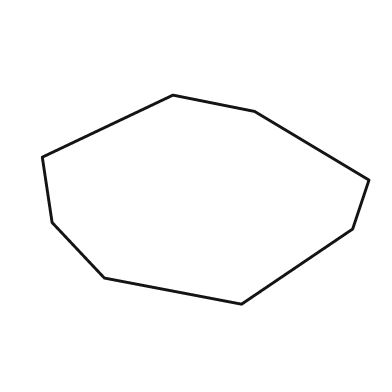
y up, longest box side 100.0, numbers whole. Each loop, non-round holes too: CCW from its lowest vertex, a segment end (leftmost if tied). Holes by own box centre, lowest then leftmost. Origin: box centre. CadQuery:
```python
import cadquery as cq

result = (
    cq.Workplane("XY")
    .moveTo(11.0, -32.0)
    .lineTo(45.0, -9.0)
    .lineTo(50.0, 6.0)
    .lineTo(15.0, 27.0)
    .lineTo(-10.0, 32.0)
    .lineTo(-50.0, 13.0)
    .lineTo(-47.0, -7.0)
    .lineTo(-31.0, -24.0)
    .close()
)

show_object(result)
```